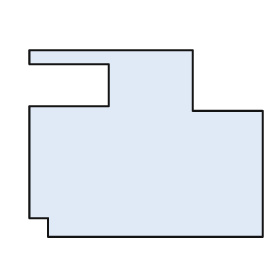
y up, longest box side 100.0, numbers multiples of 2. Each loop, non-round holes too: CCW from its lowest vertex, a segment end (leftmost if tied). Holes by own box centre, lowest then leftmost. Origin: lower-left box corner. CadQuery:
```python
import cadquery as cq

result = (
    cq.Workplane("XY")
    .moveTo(8.0, 0.0)
    .lineTo(100.0, 0.0)
    .lineTo(100.0, 54.0)
    .lineTo(70.0, 54.0)
    .lineTo(70.0, 80.0)
    .lineTo(0.0, 80.0)
    .lineTo(0.0, 74.0)
    .lineTo(34.0, 74.0)
    .lineTo(34.0, 56.0)
    .lineTo(0.0, 56.0)
    .lineTo(0.0, 8.0)
    .lineTo(8.0, 8.0)
    .close()
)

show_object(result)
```